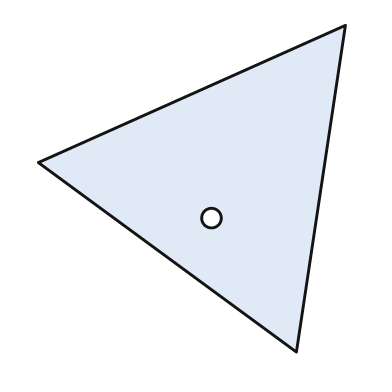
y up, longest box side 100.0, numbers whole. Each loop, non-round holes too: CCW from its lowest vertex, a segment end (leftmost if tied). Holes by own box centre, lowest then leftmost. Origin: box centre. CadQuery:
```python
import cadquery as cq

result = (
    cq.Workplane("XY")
    .moveTo(32.0, -50.0)
    .lineTo(47.0, 50.0)
    .lineTo(-47.0, 8.0)
    .close()
    .moveTo(6.0, -9.0)
    .circle(3.0)
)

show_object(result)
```